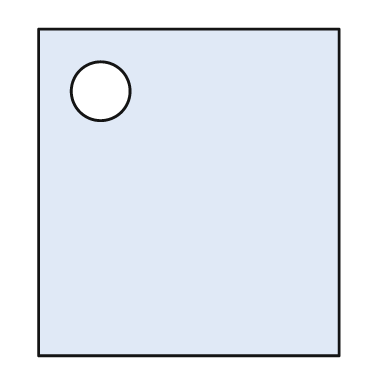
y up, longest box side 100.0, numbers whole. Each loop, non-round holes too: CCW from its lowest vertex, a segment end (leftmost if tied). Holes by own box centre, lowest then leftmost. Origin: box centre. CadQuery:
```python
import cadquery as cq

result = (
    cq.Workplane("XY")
    .moveTo(-46.0, -50.0)
    .lineTo(46.0, -50.0)
    .lineTo(46.0, 50.0)
    .lineTo(-46.0, 50.0)
    .close()
    .moveTo(-27.0, 31.0)
    .circle(9.0)
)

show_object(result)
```